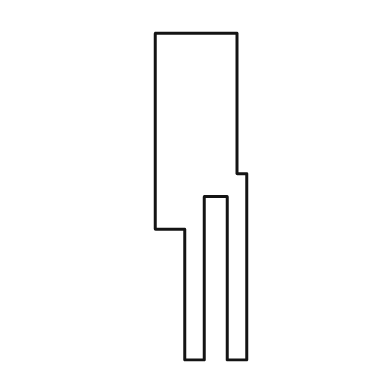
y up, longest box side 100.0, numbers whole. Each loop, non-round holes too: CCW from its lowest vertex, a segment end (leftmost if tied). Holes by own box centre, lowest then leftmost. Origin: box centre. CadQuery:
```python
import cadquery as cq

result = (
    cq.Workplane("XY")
    .moveTo(-5.0, -50.0)
    .lineTo(1.0, -50.0)
    .lineTo(1.0, 0.0)
    .lineTo(8.0, 0.0)
    .lineTo(8.0, -50.0)
    .lineTo(14.0, -50.0)
    .lineTo(14.0, 7.0)
    .lineTo(11.0, 7.0)
    .lineTo(11.0, 50.0)
    .lineTo(-14.0, 50.0)
    .lineTo(-14.0, -10.0)
    .lineTo(-5.0, -10.0)
    .close()
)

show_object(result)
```